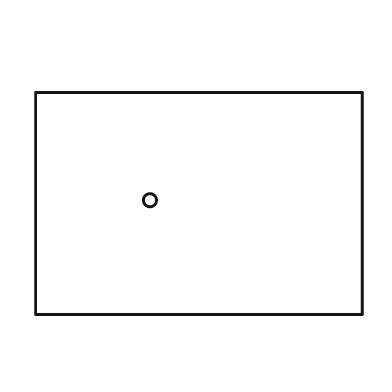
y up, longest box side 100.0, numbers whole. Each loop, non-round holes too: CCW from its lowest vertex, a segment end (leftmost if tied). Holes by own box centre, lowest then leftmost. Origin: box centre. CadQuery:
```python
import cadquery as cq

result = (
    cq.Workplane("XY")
    .moveTo(-50.0, -34.0)
    .lineTo(50.0, -34.0)
    .lineTo(50.0, 34.0)
    .lineTo(-50.0, 34.0)
    .close()
    .moveTo(-15.0, 1.0)
    .circle(2.0)
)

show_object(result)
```